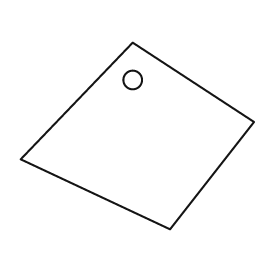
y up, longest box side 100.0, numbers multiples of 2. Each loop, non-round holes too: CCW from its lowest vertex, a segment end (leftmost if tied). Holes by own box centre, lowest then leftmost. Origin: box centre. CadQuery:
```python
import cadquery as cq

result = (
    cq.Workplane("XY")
    .moveTo(14.0, -40.0)
    .lineTo(50.0, 6.0)
    .lineTo(-2.0, 40.0)
    .lineTo(-50.0, -10.0)
    .close()
    .moveTo(-2.0, 24.0)
    .circle(4.0)
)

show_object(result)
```